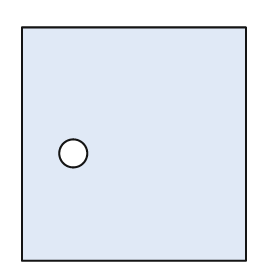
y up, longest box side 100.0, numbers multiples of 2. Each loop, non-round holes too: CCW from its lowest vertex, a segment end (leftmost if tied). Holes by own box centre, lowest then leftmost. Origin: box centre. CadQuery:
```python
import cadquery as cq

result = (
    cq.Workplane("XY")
    .moveTo(-48.0, -50.0)
    .lineTo(48.0, -50.0)
    .lineTo(48.0, 50.0)
    .lineTo(-48.0, 50.0)
    .close()
    .moveTo(-26.0, -4.0)
    .circle(6.0)
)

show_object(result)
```